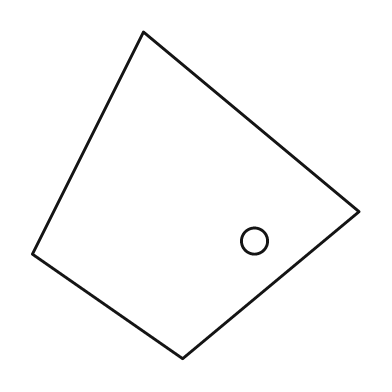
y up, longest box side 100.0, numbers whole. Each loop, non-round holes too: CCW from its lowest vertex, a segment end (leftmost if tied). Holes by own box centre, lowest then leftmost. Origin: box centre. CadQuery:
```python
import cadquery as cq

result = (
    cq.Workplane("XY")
    .moveTo(-4.0, -50.0)
    .lineTo(50.0, -5.0)
    .lineTo(-16.0, 50.0)
    .lineTo(-50.0, -18.0)
    .close()
    .moveTo(18.0, -14.0)
    .circle(4.0)
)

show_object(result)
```